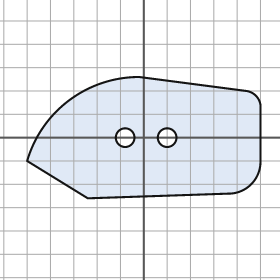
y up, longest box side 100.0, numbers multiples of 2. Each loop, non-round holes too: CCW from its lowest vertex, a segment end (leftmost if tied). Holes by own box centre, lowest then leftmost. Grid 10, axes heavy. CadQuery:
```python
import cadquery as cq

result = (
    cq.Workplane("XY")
    .moveTo(-24.0, -26.0)
    .lineTo(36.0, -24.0)
    .threePointArc((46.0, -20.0), (50.0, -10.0))
    .lineTo(50.0, 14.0)
    .threePointArc((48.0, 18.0), (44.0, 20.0))
    .lineTo(-2.0, 26.0)
    .threePointArc((-32.0, 16.0), (-50.0, -10.0))
    .close()
    .moveTo(-8.0, 0.0)
    .circle(4.0)
    .moveTo(10.0, 0.0)
    .circle(4.0)
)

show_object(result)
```